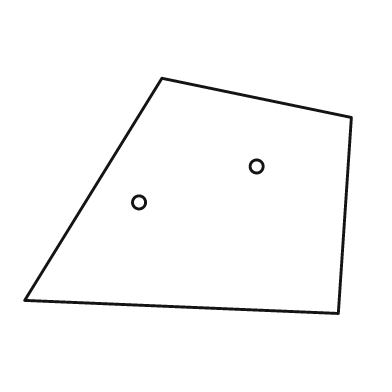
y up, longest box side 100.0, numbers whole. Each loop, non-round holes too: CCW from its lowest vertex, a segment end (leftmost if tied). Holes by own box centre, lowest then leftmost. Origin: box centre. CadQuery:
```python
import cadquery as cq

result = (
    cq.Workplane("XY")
    .moveTo(46.0, -36.0)
    .lineTo(50.0, 24.0)
    .lineTo(-8.0, 36.0)
    .lineTo(-50.0, -32.0)
    .close()
    .moveTo(-15.0, -2.0)
    .circle(2.0)
    .moveTo(21.0, 9.0)
    .circle(2.0)
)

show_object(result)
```